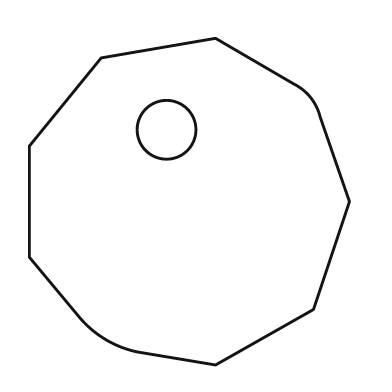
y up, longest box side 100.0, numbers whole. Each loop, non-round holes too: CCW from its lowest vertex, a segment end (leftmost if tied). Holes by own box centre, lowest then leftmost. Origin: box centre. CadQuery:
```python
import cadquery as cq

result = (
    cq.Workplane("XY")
    .moveTo(8.0, -50.0)
    .lineTo(38.0, -33.0)
    .lineTo(49.0, 0.0)
    .lineTo(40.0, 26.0)
    .threePointArc((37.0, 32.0), (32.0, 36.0))
    .lineTo(8.0, 50.0)
    .lineTo(-27.0, 44.0)
    .lineTo(-49.0, 17.0)
    .lineTo(-49.0, -17.0)
    .lineTo(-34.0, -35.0)
    .threePointArc((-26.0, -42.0), (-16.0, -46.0))
    .close()
    .moveTo(-7.0, 22.0)
    .circle(9.0)
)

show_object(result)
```